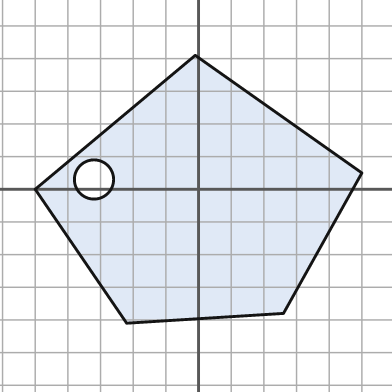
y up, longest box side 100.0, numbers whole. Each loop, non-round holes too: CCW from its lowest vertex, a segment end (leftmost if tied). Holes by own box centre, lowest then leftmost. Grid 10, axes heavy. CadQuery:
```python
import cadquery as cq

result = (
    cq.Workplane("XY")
    .moveTo(-22.0, -41.0)
    .lineTo(26.0, -38.0)
    .lineTo(50.0, 5.0)
    .lineTo(-1.0, 41.0)
    .lineTo(-50.0, 0.0)
    .close()
    .moveTo(-32.0, 3.0)
    .circle(6.0)
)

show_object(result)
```